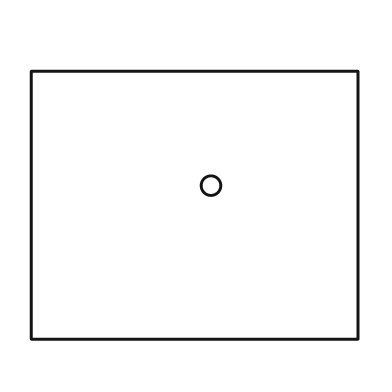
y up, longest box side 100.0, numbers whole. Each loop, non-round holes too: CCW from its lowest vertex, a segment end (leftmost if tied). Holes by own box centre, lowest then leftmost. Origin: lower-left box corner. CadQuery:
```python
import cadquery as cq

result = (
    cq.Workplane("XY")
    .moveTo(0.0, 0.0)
    .lineTo(100.0, 0.0)
    .lineTo(100.0, 82.0)
    .lineTo(0.0, 82.0)
    .close()
    .moveTo(55.0, 47.0)
    .circle(3.0)
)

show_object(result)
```